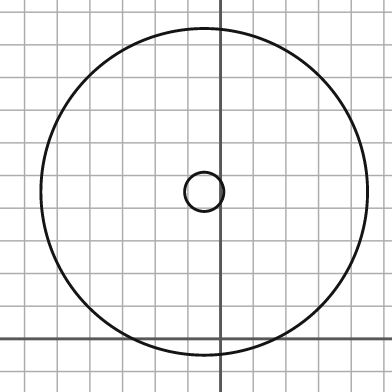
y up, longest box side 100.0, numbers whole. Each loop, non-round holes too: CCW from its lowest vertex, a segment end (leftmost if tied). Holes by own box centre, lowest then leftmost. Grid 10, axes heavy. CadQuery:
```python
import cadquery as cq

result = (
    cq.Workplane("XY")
    .moveTo(-5.0, 45.0)
    .circle(50.0)
    .moveTo(-5.0, 45.0)
    .circle(6.0)
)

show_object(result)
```